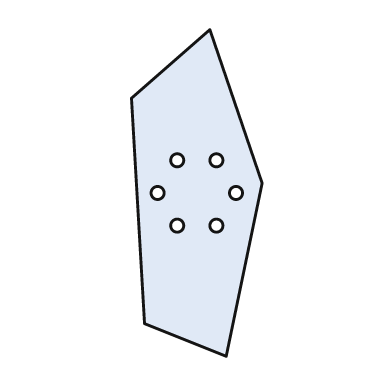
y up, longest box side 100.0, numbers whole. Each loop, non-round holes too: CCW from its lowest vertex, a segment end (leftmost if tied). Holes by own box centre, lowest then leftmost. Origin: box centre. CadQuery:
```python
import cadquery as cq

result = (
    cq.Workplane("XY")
    .moveTo(9.0, -50.0)
    .lineTo(20.0, 3.0)
    .lineTo(4.0, 50.0)
    .lineTo(-20.0, 29.0)
    .lineTo(-16.0, -40.0)
    .close()
    .moveTo(-6.0, -10.0)
    .circle(2.0)
    .moveTo(6.0, -10.0)
    .circle(2.0)
    .moveTo(-12.0, 0.0)
    .circle(2.0)
    .moveTo(12.0, 0.0)
    .circle(2.0)
    .moveTo(-6.0, 10.0)
    .circle(2.0)
    .moveTo(6.0, 10.0)
    .circle(2.0)
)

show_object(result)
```